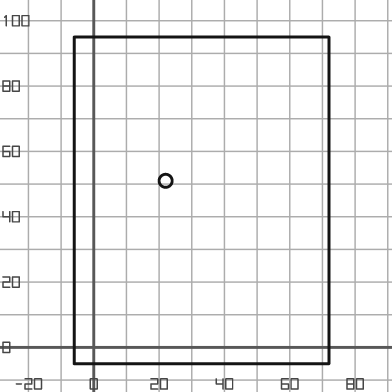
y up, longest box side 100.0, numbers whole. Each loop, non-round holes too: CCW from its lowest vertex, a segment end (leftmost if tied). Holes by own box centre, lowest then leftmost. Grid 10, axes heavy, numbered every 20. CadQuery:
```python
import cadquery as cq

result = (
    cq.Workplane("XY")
    .moveTo(-6.0, -5.0)
    .lineTo(72.0, -5.0)
    .lineTo(72.0, 95.0)
    .lineTo(-6.0, 95.0)
    .close()
    .moveTo(22.0, 51.0)
    .circle(2.0)
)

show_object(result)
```